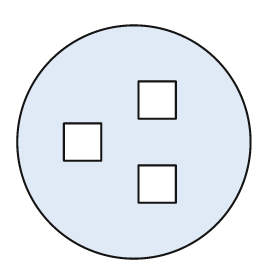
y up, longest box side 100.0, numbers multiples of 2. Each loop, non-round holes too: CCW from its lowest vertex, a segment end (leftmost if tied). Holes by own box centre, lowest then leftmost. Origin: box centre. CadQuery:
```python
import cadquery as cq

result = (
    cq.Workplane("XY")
    .moveTo(0.0, 0.0)
    .circle(50.0)
    .moveTo(2.0, -26.0)
    .lineTo(18.0, -26.0)
    .lineTo(18.0, -10.0)
    .lineTo(2.0, -10.0)
    .close()
    .moveTo(-30.0, -8.0)
    .lineTo(-14.0, -8.0)
    .lineTo(-14.0, 8.0)
    .lineTo(-30.0, 8.0)
    .close()
    .moveTo(2.0, 10.0)
    .lineTo(18.0, 10.0)
    .lineTo(18.0, 26.0)
    .lineTo(2.0, 26.0)
    .close()
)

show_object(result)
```